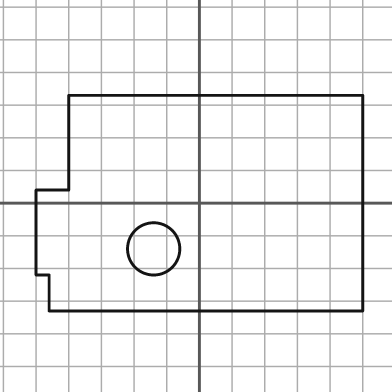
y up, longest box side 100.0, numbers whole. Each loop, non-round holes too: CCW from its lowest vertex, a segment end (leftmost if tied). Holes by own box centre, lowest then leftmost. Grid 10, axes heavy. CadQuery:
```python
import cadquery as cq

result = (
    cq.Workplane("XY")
    .moveTo(-46.0, -33.0)
    .lineTo(50.0, -33.0)
    .lineTo(50.0, 33.0)
    .lineTo(-40.0, 33.0)
    .lineTo(-40.0, 4.0)
    .lineTo(-50.0, 4.0)
    .lineTo(-50.0, -22.0)
    .lineTo(-46.0, -22.0)
    .close()
    .moveTo(-14.0, -14.0)
    .circle(8.0)
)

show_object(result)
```